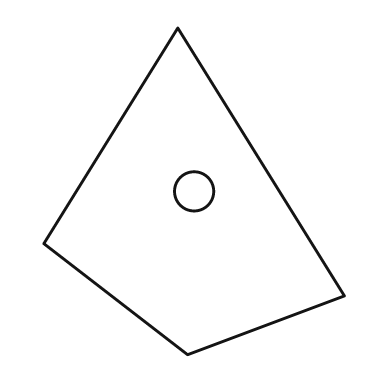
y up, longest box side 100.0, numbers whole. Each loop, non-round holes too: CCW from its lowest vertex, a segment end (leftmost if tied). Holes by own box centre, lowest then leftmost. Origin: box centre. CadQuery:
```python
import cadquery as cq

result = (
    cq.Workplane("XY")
    .moveTo(-2.0, -50.0)
    .lineTo(46.0, -32.0)
    .lineTo(-5.0, 50.0)
    .lineTo(-46.0, -16.0)
    .close()
    .moveTo(0.0, 0.0)
    .circle(6.0)
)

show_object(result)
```